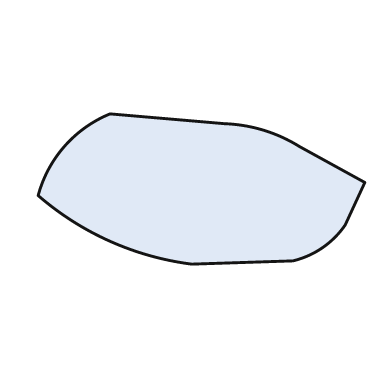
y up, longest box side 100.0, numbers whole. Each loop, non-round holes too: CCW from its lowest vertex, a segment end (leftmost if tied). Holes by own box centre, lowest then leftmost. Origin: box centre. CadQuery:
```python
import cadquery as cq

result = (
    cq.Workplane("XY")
    .moveTo(-3.0, -23.0)
    .lineTo(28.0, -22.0)
    .threePointArc((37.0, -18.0), (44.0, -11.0))
    .lineTo(50.0, 2.0)
    .lineTo(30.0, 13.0)
    .threePointArc((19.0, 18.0), (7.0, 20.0))
    .lineTo(-28.0, 23.0)
    .threePointArc((-42.0, 13.0), (-50.0, -2.0))
    .threePointArc((-28.0, -16.0), (-3.0, -23.0))
    .close()
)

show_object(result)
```